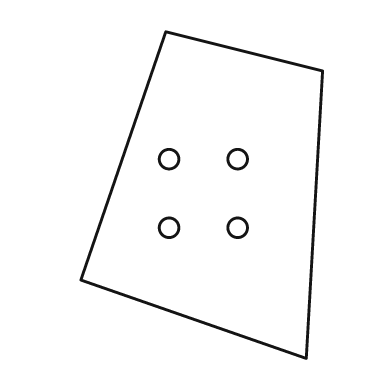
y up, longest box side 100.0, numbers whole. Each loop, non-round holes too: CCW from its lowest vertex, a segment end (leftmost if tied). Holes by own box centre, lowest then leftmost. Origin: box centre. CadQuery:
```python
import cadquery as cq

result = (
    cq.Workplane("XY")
    .moveTo(32.0, -50.0)
    .lineTo(37.0, 38.0)
    .lineTo(-11.0, 50.0)
    .lineTo(-37.0, -26.0)
    .close()
    .moveTo(-10.0, -10.0)
    .circle(3.0)
    .moveTo(11.0, -10.0)
    .circle(3.0)
    .moveTo(-10.0, 11.0)
    .circle(3.0)
    .moveTo(11.0, 11.0)
    .circle(3.0)
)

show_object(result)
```